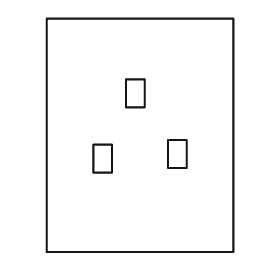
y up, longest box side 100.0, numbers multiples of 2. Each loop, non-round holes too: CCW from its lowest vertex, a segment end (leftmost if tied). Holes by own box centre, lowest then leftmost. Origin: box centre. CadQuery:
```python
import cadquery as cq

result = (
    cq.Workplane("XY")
    .moveTo(-40.0, -50.0)
    .lineTo(40.0, -50.0)
    .lineTo(40.0, 50.0)
    .lineTo(-40.0, 50.0)
    .close()
    .moveTo(-20.0, -16.0)
    .lineTo(-12.0, -16.0)
    .lineTo(-12.0, -4.0)
    .lineTo(-20.0, -4.0)
    .close()
    .moveTo(12.0, -14.0)
    .lineTo(20.0, -14.0)
    .lineTo(20.0, -2.0)
    .lineTo(12.0, -2.0)
    .close()
    .moveTo(-6.0, 12.0)
    .lineTo(2.0, 12.0)
    .lineTo(2.0, 24.0)
    .lineTo(-6.0, 24.0)
    .close()
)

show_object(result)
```